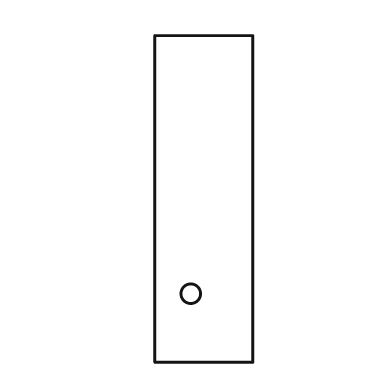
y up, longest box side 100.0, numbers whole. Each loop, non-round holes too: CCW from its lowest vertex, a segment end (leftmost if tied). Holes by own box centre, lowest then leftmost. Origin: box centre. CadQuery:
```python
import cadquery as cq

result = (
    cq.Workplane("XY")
    .moveTo(-15.0, -50.0)
    .lineTo(15.0, -50.0)
    .lineTo(15.0, 50.0)
    .lineTo(-15.0, 50.0)
    .close()
    .moveTo(-4.0, -29.0)
    .circle(3.0)
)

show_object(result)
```